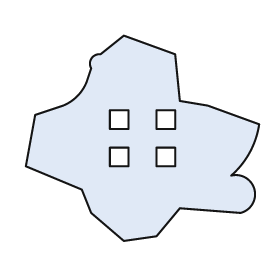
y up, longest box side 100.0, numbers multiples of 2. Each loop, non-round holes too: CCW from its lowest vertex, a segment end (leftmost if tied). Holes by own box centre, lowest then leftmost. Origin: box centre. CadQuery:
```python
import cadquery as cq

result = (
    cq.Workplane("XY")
    .moveTo(-8.0, -44.0)
    .lineTo(6.0, -42.0)
    .lineTo(16.0, -30.0)
    .lineTo(42.0, -32.0)
    .threePointArc((48.0, -22.0), (38.0, -16.0))
    .threePointArc((46.0, -6.0), (50.0, 6.0))
    .lineTo(28.0, 14.0)
    .lineTo(16.0, 16.0)
    .lineTo(14.0, 36.0)
    .lineTo(-8.0, 44.0)
    .lineTo(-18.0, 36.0)
    .threePointArc((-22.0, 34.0), (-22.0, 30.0))
    .lineTo(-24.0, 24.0)
    .threePointArc((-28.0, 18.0), (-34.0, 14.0))
    .lineTo(-46.0, 10.0)
    .lineTo(-50.0, -12.0)
    .lineTo(-26.0, -22.0)
    .lineTo(-22.0, -32.0)
    .close()
    .moveTo(-14.0, -12.0)
    .lineTo(-6.0, -12.0)
    .lineTo(-6.0, -4.0)
    .lineTo(-14.0, -4.0)
    .close()
    .moveTo(6.0, -12.0)
    .lineTo(14.0, -12.0)
    .lineTo(14.0, -4.0)
    .lineTo(6.0, -4.0)
    .close()
    .moveTo(-14.0, 4.0)
    .lineTo(-6.0, 4.0)
    .lineTo(-6.0, 12.0)
    .lineTo(-14.0, 12.0)
    .close()
    .moveTo(6.0, 4.0)
    .lineTo(14.0, 4.0)
    .lineTo(14.0, 12.0)
    .lineTo(6.0, 12.0)
    .close()
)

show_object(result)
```